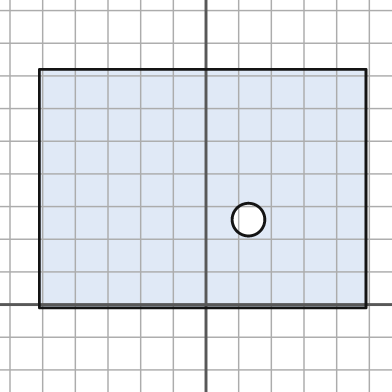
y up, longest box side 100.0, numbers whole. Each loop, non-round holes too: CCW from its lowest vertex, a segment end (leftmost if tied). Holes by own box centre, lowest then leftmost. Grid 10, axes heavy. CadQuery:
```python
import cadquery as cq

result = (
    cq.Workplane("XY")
    .moveTo(-51.0, -1.0)
    .lineTo(49.0, -1.0)
    .lineTo(49.0, 72.0)
    .lineTo(-51.0, 72.0)
    .close()
    .moveTo(13.0, 26.0)
    .circle(5.0)
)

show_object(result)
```